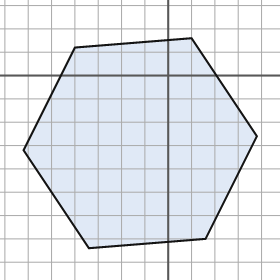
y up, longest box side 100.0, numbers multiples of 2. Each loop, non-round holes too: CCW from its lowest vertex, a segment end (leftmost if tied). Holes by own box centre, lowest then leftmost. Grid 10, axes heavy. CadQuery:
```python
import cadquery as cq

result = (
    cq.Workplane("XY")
    .moveTo(-34.0, -74.0)
    .lineTo(16.0, -70.0)
    .lineTo(38.0, -26.0)
    .lineTo(10.0, 16.0)
    .lineTo(-40.0, 12.0)
    .lineTo(-62.0, -32.0)
    .close()
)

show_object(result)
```